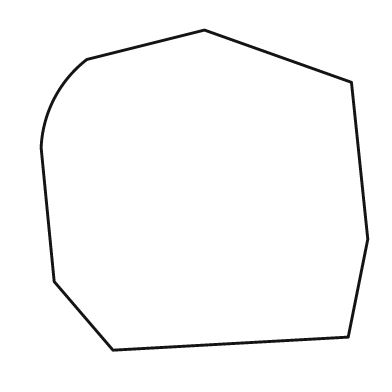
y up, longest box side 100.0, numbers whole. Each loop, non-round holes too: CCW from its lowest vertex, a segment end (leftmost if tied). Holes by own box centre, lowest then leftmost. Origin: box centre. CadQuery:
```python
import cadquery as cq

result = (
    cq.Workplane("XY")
    .moveTo(-28.0, -49.0)
    .lineTo(44.0, -45.0)
    .lineTo(50.0, -15.0)
    .lineTo(45.0, 33.0)
    .lineTo(0.0, 49.0)
    .lineTo(-36.0, 40.0)
    .threePointArc((-46.0, 28.0), (-50.0, 13.0))
    .lineTo(-46.0, -28.0)
    .close()
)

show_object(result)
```